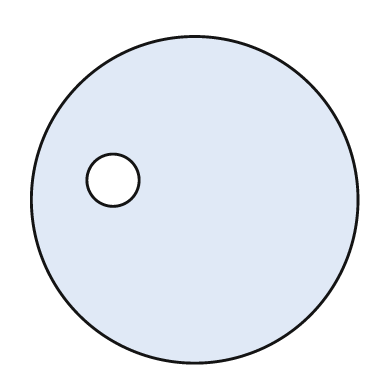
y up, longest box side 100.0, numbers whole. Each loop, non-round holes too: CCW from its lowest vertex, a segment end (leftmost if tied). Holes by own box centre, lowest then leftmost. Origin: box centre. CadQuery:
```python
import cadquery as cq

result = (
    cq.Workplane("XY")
    .moveTo(0.0, 0.0)
    .circle(50.0)
    .moveTo(-25.0, 6.0)
    .circle(8.0)
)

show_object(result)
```